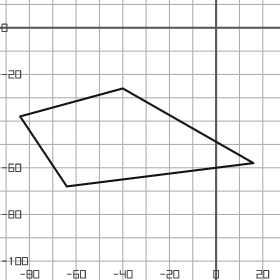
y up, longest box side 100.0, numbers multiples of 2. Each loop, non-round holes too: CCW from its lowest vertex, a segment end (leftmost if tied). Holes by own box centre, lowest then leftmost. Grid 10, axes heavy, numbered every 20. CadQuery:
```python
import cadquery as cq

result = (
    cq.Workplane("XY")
    .moveTo(-64.0, -68.0)
    .lineTo(16.0, -58.0)
    .lineTo(-40.0, -26.0)
    .lineTo(-84.0, -38.0)
    .close()
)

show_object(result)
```